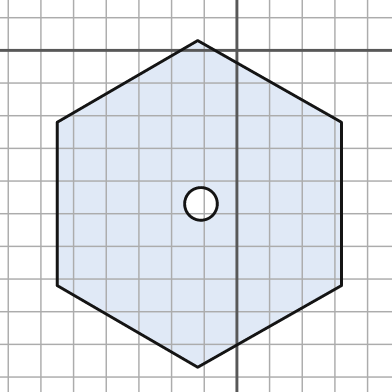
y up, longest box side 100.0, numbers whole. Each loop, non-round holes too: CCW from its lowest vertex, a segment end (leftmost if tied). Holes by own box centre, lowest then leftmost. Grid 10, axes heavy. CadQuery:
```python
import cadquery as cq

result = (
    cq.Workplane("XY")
    .moveTo(-12.0, -97.0)
    .lineTo(32.0, -72.0)
    .lineTo(32.0, -22.0)
    .lineTo(-12.0, 3.0)
    .lineTo(-55.0, -22.0)
    .lineTo(-55.0, -72.0)
    .close()
    .moveTo(-11.0, -47.0)
    .circle(5.0)
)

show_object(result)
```